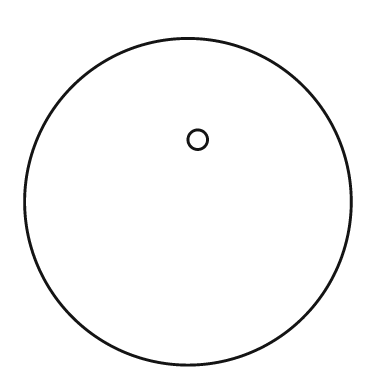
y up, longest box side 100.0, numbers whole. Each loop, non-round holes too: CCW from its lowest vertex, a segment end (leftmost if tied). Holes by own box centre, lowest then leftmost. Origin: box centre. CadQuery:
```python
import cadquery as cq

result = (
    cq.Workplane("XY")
    .moveTo(0.0, 0.0)
    .circle(50.0)
    .moveTo(3.0, 19.0)
    .circle(3.0)
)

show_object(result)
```